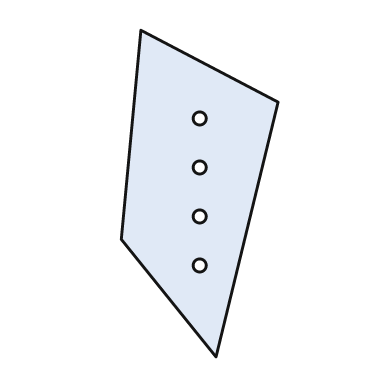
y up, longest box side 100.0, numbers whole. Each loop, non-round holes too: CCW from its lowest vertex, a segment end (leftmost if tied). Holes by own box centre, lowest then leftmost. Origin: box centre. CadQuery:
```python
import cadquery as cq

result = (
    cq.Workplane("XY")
    .moveTo(5.0, -50.0)
    .lineTo(24.0, 28.0)
    .lineTo(-18.0, 50.0)
    .lineTo(-24.0, -14.0)
    .close()
    .moveTo(0.0, -22.0)
    .circle(2.0)
    .moveTo(0.0, -7.0)
    .circle(2.0)
    .moveTo(0.0, 8.0)
    .circle(2.0)
    .moveTo(0.0, 23.0)
    .circle(2.0)
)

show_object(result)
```